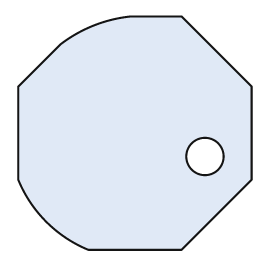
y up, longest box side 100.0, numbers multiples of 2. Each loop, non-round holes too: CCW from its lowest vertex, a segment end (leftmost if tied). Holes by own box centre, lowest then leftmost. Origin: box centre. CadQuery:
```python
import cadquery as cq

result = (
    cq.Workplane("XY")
    .moveTo(-20.0, -50.0)
    .lineTo(20.0, -50.0)
    .lineTo(50.0, -20.0)
    .lineTo(50.0, 20.0)
    .lineTo(20.0, 50.0)
    .lineTo(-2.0, 50.0)
    .threePointArc((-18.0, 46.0), (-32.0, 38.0))
    .lineTo(-50.0, 20.0)
    .lineTo(-50.0, -20.0)
    .threePointArc((-38.0, -38.0), (-20.0, -50.0))
    .close()
    .moveTo(30.0, -10.0)
    .circle(8.0)
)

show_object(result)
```